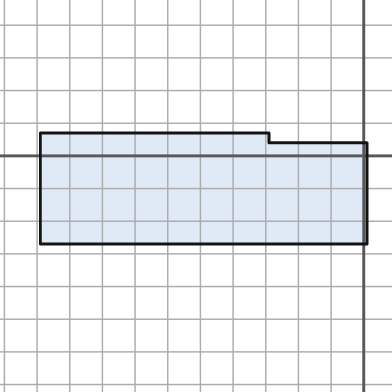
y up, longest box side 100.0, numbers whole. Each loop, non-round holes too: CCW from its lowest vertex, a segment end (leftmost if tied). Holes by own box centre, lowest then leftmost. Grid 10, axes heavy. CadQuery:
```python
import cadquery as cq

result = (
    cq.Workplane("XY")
    .moveTo(-99.0, -27.0)
    .lineTo(1.0, -27.0)
    .lineTo(1.0, 4.0)
    .lineTo(-29.0, 4.0)
    .lineTo(-29.0, 7.0)
    .lineTo(-99.0, 7.0)
    .close()
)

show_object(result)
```